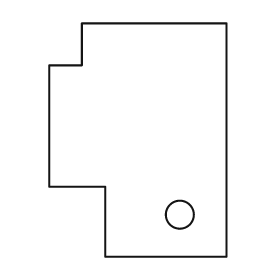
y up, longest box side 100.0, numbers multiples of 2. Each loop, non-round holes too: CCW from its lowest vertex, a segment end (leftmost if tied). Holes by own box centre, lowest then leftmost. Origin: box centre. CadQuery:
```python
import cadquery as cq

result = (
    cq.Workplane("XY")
    .moveTo(-14.0, -50.0)
    .lineTo(38.0, -50.0)
    .lineTo(38.0, 50.0)
    .lineTo(-24.0, 50.0)
    .lineTo(-24.0, 32.0)
    .lineTo(-38.0, 32.0)
    .lineTo(-38.0, -20.0)
    .lineTo(-14.0, -20.0)
    .close()
    .moveTo(18.0, -32.0)
    .circle(6.0)
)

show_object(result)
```